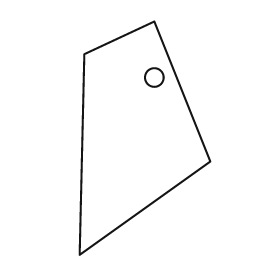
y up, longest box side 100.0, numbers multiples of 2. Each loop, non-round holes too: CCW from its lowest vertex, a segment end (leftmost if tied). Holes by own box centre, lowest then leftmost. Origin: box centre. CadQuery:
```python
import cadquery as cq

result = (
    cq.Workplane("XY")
    .moveTo(-28.0, -50.0)
    .lineTo(28.0, -10.0)
    .lineTo(4.0, 50.0)
    .lineTo(-26.0, 36.0)
    .close()
    .moveTo(4.0, 26.0)
    .circle(4.0)
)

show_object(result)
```